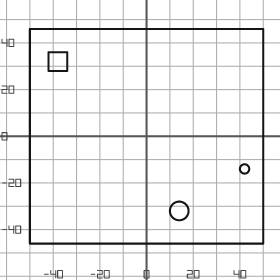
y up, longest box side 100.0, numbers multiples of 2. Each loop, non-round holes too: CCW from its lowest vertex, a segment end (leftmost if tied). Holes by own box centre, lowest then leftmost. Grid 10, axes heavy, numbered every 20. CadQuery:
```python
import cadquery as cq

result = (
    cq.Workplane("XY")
    .moveTo(-50.0, -46.0)
    .lineTo(50.0, -46.0)
    .lineTo(50.0, 46.0)
    .lineTo(-50.0, 46.0)
    .close()
    .moveTo(14.0, -32.0)
    .circle(4.0)
    .moveTo(42.0, -14.0)
    .circle(2.0)
    .moveTo(-42.0, 28.0)
    .lineTo(-34.0, 28.0)
    .lineTo(-34.0, 36.0)
    .lineTo(-42.0, 36.0)
    .close()
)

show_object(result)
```